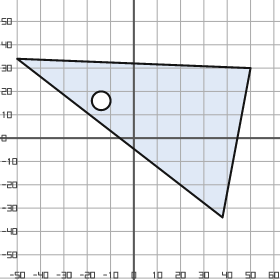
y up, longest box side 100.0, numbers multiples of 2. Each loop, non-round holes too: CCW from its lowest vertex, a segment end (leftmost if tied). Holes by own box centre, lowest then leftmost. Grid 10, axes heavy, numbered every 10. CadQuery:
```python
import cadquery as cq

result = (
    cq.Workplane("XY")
    .moveTo(38.0, -34.0)
    .lineTo(50.0, 30.0)
    .lineTo(-50.0, 34.0)
    .close()
    .moveTo(-14.0, 16.0)
    .circle(4.0)
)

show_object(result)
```